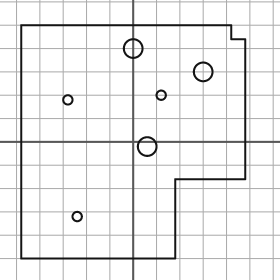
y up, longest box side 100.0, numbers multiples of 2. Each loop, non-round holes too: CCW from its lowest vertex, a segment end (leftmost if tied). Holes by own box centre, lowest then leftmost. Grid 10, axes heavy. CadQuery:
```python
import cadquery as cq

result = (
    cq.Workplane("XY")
    .moveTo(-48.0, -50.0)
    .lineTo(18.0, -50.0)
    .lineTo(18.0, -16.0)
    .lineTo(48.0, -16.0)
    .lineTo(48.0, 44.0)
    .lineTo(42.0, 44.0)
    .lineTo(42.0, 50.0)
    .lineTo(-48.0, 50.0)
    .close()
    .moveTo(-24.0, -32.0)
    .circle(2.0)
    .moveTo(6.0, -2.0)
    .circle(4.0)
    .moveTo(-28.0, 18.0)
    .circle(2.0)
    .moveTo(12.0, 20.0)
    .circle(2.0)
    .moveTo(30.0, 30.0)
    .circle(4.0)
    .moveTo(0.0, 40.0)
    .circle(4.0)
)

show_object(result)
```